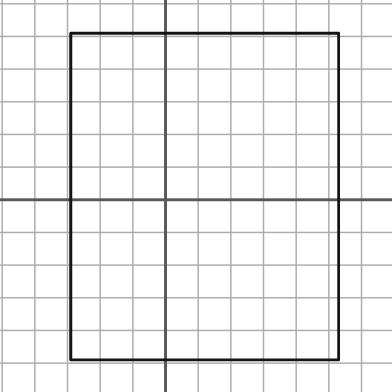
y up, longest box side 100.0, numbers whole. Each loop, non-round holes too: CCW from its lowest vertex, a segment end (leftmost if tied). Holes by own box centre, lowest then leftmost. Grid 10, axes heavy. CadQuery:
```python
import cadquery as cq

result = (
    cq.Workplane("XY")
    .moveTo(-29.0, -49.0)
    .lineTo(53.0, -49.0)
    .lineTo(53.0, 51.0)
    .lineTo(-29.0, 51.0)
    .close()
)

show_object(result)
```